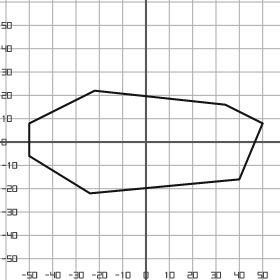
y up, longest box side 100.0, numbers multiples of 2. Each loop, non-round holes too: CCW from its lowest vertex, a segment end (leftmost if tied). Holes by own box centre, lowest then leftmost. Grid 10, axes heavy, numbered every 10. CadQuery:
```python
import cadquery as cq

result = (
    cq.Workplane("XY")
    .moveTo(-24.0, -22.0)
    .lineTo(40.0, -16.0)
    .lineTo(50.0, 8.0)
    .lineTo(34.0, 16.0)
    .lineTo(-22.0, 22.0)
    .lineTo(-50.0, 8.0)
    .lineTo(-50.0, -6.0)
    .close()
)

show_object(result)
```